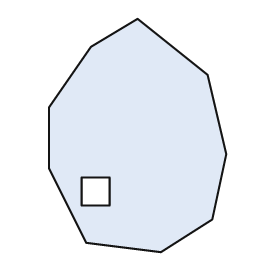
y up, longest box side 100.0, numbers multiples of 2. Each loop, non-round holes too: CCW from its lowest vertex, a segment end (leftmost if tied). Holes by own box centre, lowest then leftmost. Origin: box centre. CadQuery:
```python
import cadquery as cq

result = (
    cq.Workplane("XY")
    .moveTo(10.0, -50.0)
    .lineTo(32.0, -36.0)
    .lineTo(38.0, -8.0)
    .lineTo(30.0, 26.0)
    .lineTo(0.0, 50.0)
    .lineTo(-20.0, 38.0)
    .lineTo(-38.0, 12.0)
    .lineTo(-38.0, -14.0)
    .lineTo(-22.0, -46.0)
    .close()
    .moveTo(-24.0, -30.0)
    .lineTo(-12.0, -30.0)
    .lineTo(-12.0, -18.0)
    .lineTo(-24.0, -18.0)
    .close()
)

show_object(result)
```